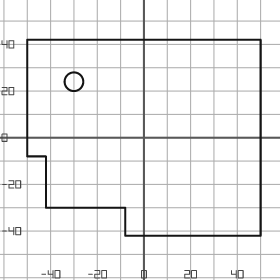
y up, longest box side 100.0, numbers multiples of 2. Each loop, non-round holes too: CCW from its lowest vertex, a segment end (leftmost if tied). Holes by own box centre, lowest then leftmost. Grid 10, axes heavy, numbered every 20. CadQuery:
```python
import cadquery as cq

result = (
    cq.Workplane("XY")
    .moveTo(-8.0, -42.0)
    .lineTo(50.0, -42.0)
    .lineTo(50.0, 42.0)
    .lineTo(-50.0, 42.0)
    .lineTo(-50.0, -8.0)
    .lineTo(-42.0, -8.0)
    .lineTo(-42.0, -30.0)
    .lineTo(-8.0, -30.0)
    .close()
    .moveTo(-30.0, 24.0)
    .circle(4.0)
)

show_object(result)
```